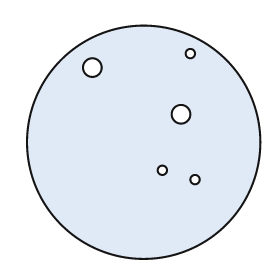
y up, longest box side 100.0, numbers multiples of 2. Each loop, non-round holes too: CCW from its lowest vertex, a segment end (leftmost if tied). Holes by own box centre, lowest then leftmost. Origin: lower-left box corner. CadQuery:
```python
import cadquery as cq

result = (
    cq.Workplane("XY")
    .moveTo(50.0, 50.0)
    .circle(50.0)
    .moveTo(72.0, 34.0)
    .circle(2.0)
    .moveTo(58.0, 38.0)
    .circle(2.0)
    .moveTo(66.0, 62.0)
    .circle(4.0)
    .moveTo(28.0, 82.0)
    .circle(4.0)
    .moveTo(70.0, 88.0)
    .circle(2.0)
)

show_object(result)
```